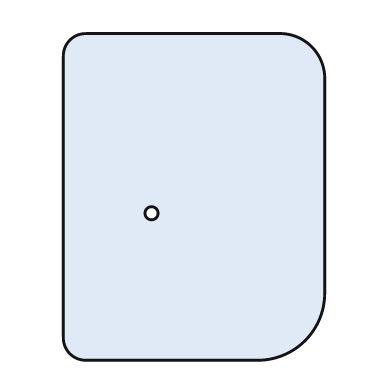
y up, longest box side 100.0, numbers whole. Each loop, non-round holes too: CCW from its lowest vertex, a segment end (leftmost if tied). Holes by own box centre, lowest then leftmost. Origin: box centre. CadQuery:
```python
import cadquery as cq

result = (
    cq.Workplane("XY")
    .moveTo(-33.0, -50.0)
    .lineTo(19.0, -50.0)
    .threePointArc((34.0, -44.0), (40.0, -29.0))
    .lineTo(40.0, 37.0)
    .threePointArc((36.0, 46.0), (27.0, 50.0))
    .lineTo(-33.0, 50.0)
    .threePointArc((-38.0, 48.0), (-40.0, 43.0))
    .lineTo(-40.0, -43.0)
    .threePointArc((-38.0, -48.0), (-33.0, -50.0))
    .close()
    .moveTo(-13.0, -5.0)
    .circle(2.0)
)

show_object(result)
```